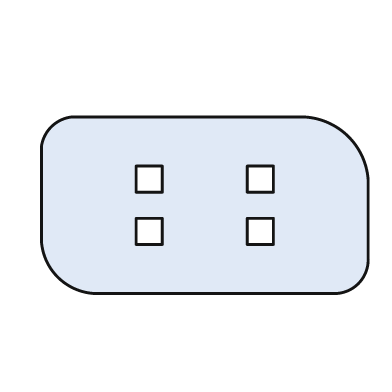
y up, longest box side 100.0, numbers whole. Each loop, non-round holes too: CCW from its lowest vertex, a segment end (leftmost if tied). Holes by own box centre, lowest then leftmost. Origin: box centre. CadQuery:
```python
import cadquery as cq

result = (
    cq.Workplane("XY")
    .moveTo(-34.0, -27.0)
    .lineTo(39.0, -27.0)
    .threePointArc((47.0, -24.0), (50.0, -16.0))
    .lineTo(50.0, 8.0)
    .threePointArc((44.0, 21.0), (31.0, 27.0))
    .lineTo(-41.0, 27.0)
    .threePointArc((-47.0, 24.0), (-50.0, 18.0))
    .lineTo(-50.0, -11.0)
    .threePointArc((-45.0, -22.0), (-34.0, -27.0))
    .close()
    .moveTo(-21.0, -12.0)
    .lineTo(-13.0, -12.0)
    .lineTo(-13.0, -4.0)
    .lineTo(-21.0, -4.0)
    .close()
    .moveTo(13.0, -12.0)
    .lineTo(21.0, -12.0)
    .lineTo(21.0, -4.0)
    .lineTo(13.0, -4.0)
    .close()
    .moveTo(-21.0, 4.0)
    .lineTo(-13.0, 4.0)
    .lineTo(-13.0, 12.0)
    .lineTo(-21.0, 12.0)
    .close()
    .moveTo(13.0, 4.0)
    .lineTo(21.0, 4.0)
    .lineTo(21.0, 12.0)
    .lineTo(13.0, 12.0)
    .close()
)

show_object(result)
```